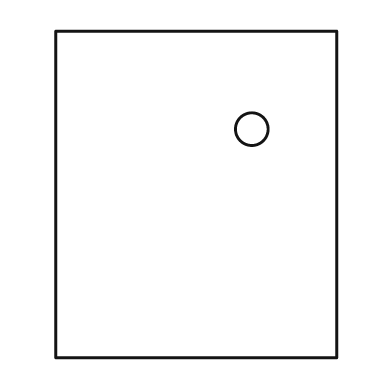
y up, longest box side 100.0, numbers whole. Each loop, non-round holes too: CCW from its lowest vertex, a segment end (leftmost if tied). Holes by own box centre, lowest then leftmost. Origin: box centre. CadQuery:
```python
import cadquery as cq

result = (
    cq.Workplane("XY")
    .moveTo(-43.0, -50.0)
    .lineTo(43.0, -50.0)
    .lineTo(43.0, 50.0)
    .lineTo(-43.0, 50.0)
    .close()
    .moveTo(17.0, 20.0)
    .circle(5.0)
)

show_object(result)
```